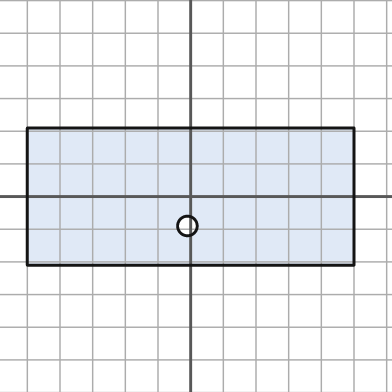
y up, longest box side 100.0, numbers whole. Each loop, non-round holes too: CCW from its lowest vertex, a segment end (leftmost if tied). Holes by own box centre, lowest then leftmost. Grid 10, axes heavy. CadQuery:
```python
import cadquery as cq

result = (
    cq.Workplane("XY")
    .moveTo(-50.0, -21.0)
    .lineTo(50.0, -21.0)
    .lineTo(50.0, 21.0)
    .lineTo(-50.0, 21.0)
    .close()
    .moveTo(-1.0, -9.0)
    .circle(3.0)
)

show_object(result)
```